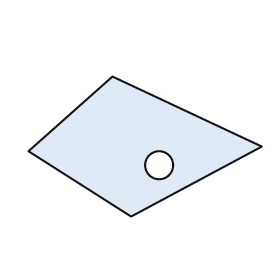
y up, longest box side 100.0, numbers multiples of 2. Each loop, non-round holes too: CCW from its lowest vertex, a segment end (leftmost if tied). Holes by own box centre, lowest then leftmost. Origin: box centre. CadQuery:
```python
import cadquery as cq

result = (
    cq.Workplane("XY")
    .moveTo(-6.0, -30.0)
    .lineTo(50.0, 0.0)
    .lineTo(-14.0, 30.0)
    .lineTo(-50.0, -2.0)
    .close()
    .moveTo(6.0, -8.0)
    .circle(6.0)
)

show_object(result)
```